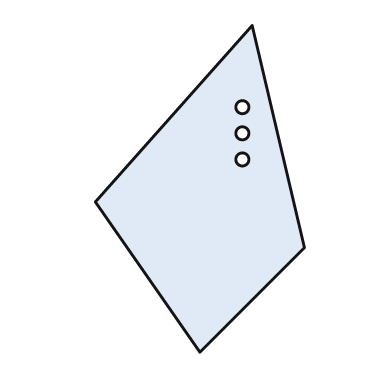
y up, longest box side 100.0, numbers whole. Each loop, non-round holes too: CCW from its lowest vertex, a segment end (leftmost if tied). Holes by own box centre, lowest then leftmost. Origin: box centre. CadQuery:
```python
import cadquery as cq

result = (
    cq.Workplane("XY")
    .moveTo(0.0, -50.0)
    .lineTo(32.0, -18.0)
    .lineTo(16.0, 50.0)
    .lineTo(-32.0, -4.0)
    .close()
    .moveTo(13.0, 9.0)
    .circle(2.0)
    .moveTo(13.0, 17.0)
    .circle(2.0)
    .moveTo(13.0, 25.0)
    .circle(2.0)
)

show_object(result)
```